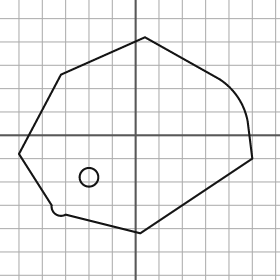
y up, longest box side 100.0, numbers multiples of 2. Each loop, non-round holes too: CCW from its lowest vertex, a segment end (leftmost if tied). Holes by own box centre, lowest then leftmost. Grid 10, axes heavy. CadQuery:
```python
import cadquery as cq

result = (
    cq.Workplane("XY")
    .moveTo(2.0, -42.0)
    .lineTo(50.0, -10.0)
    .lineTo(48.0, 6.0)
    .threePointArc((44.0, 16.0), (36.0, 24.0))
    .lineTo(4.0, 42.0)
    .lineTo(-32.0, 26.0)
    .lineTo(-50.0, -8.0)
    .lineTo(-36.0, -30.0)
    .threePointArc((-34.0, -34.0), (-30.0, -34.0))
    .close()
    .moveTo(-20.0, -18.0)
    .circle(4.0)
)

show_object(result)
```